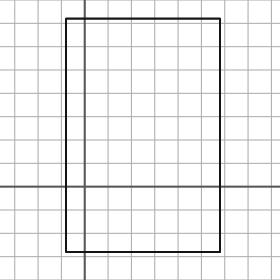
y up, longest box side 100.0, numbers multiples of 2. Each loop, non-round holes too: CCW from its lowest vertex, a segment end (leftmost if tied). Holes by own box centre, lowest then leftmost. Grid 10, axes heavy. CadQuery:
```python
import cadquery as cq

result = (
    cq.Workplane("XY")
    .moveTo(-8.0, -28.0)
    .lineTo(58.0, -28.0)
    .lineTo(58.0, 72.0)
    .lineTo(-8.0, 72.0)
    .close()
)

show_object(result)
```